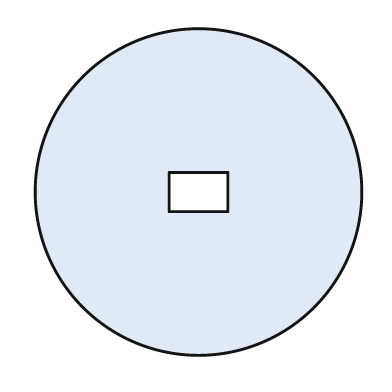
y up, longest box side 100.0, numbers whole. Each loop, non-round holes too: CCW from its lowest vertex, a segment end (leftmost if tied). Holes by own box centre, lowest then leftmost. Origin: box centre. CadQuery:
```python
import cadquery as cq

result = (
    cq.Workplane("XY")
    .moveTo(0.0, 0.0)
    .circle(50.0)
    .moveTo(-9.0, -6.0)
    .lineTo(9.0, -6.0)
    .lineTo(9.0, 6.0)
    .lineTo(-9.0, 6.0)
    .close()
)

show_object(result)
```